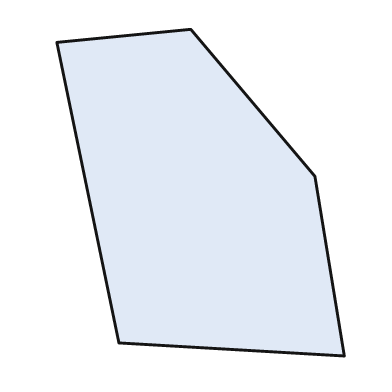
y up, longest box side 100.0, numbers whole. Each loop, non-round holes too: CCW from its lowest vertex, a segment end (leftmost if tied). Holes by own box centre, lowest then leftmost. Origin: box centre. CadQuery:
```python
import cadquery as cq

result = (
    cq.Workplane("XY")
    .moveTo(44.0, -50.0)
    .lineTo(35.0, 5.0)
    .lineTo(-3.0, 50.0)
    .lineTo(-44.0, 46.0)
    .lineTo(-25.0, -46.0)
    .close()
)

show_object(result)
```